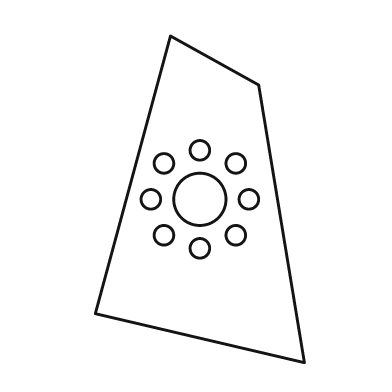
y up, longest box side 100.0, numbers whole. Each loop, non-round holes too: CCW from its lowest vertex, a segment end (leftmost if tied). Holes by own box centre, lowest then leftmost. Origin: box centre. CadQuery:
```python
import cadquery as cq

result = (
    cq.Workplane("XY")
    .moveTo(32.0, -50.0)
    .lineTo(18.0, 35.0)
    .lineTo(-9.0, 50.0)
    .lineTo(-32.0, -35.0)
    .close()
    .moveTo(0.0, -15.0)
    .circle(3.0)
    .moveTo(-11.0, -11.0)
    .circle(3.0)
    .moveTo(11.0, -11.0)
    .circle(3.0)
    .moveTo(-15.0, 0.0)
    .circle(3.0)
    .moveTo(0.0, 0.0)
    .circle(8.0)
    .moveTo(15.0, 0.0)
    .circle(3.0)
    .moveTo(-11.0, 11.0)
    .circle(3.0)
    .moveTo(11.0, 11.0)
    .circle(3.0)
    .moveTo(0.0, 15.0)
    .circle(3.0)
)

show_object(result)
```